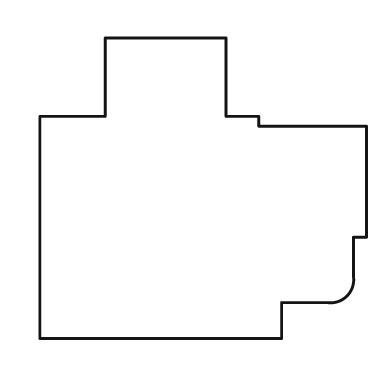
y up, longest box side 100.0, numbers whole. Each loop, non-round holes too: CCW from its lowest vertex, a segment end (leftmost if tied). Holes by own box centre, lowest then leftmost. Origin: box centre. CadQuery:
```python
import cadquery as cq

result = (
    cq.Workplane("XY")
    .moveTo(-50.0, -46.0)
    .lineTo(24.0, -46.0)
    .lineTo(24.0, -35.0)
    .lineTo(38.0, -35.0)
    .threePointArc((44.0, -33.0), (46.0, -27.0))
    .lineTo(46.0, -15.0)
    .lineTo(50.0, -15.0)
    .lineTo(50.0, 19.0)
    .lineTo(17.0, 19.0)
    .lineTo(17.0, 22.0)
    .lineTo(7.0, 22.0)
    .lineTo(7.0, 46.0)
    .lineTo(-30.0, 46.0)
    .lineTo(-30.0, 22.0)
    .lineTo(-50.0, 22.0)
    .close()
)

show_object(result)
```